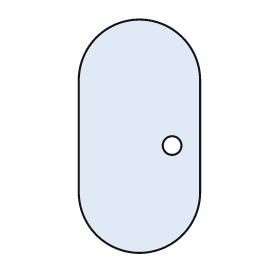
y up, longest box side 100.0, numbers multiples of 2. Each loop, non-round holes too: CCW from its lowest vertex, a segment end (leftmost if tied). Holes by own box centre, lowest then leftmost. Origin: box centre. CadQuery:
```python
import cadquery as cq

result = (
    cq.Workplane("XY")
    .moveTo(-26.0, -24.0)
    .threePointArc((0.0, -50.0), (26.0, -24.0))
    .lineTo(26.0, 24.0)
    .threePointArc((0.0, 50.0), (-26.0, 24.0))
    .close()
    .moveTo(14.0, -4.0)
    .circle(4.0)
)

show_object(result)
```